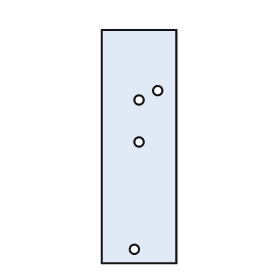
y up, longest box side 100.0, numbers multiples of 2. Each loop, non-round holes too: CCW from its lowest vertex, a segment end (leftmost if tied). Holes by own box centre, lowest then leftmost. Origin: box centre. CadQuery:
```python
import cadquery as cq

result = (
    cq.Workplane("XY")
    .moveTo(-16.0, -50.0)
    .lineTo(16.0, -50.0)
    .lineTo(16.0, 50.0)
    .lineTo(-16.0, 50.0)
    .close()
    .moveTo(-2.0, -44.0)
    .circle(2.0)
    .moveTo(0.0, 2.0)
    .circle(2.0)
    .moveTo(0.0, 20.0)
    .circle(2.0)
    .moveTo(8.0, 24.0)
    .circle(2.0)
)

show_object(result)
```